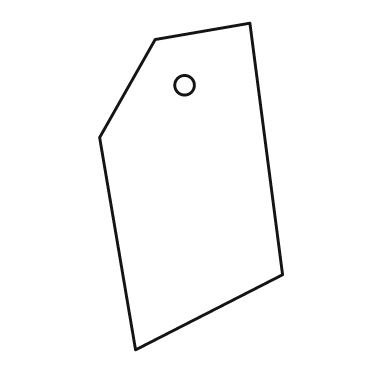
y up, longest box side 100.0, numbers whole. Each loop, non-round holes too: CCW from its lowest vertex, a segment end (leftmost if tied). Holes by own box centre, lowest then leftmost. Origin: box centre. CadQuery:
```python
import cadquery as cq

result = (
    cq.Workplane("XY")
    .moveTo(-17.0, -50.0)
    .lineTo(28.0, -27.0)
    .lineTo(18.0, 50.0)
    .lineTo(-11.0, 45.0)
    .lineTo(-28.0, 15.0)
    .close()
    .moveTo(-2.0, 31.0)
    .circle(3.0)
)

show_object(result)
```